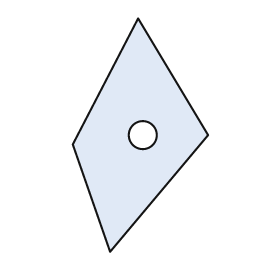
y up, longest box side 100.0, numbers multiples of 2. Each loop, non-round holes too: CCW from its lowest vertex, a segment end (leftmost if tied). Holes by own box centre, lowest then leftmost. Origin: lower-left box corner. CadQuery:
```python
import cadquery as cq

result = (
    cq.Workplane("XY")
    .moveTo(16.0, 0.0)
    .lineTo(58.0, 50.0)
    .lineTo(28.0, 100.0)
    .lineTo(0.0, 46.0)
    .close()
    .moveTo(30.0, 50.0)
    .circle(6.0)
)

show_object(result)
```